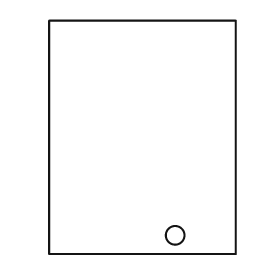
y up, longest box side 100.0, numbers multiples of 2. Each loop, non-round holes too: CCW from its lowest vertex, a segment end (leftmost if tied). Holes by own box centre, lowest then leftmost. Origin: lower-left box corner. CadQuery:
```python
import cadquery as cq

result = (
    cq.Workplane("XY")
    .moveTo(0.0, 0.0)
    .lineTo(80.0, 0.0)
    .lineTo(80.0, 100.0)
    .lineTo(0.0, 100.0)
    .close()
    .moveTo(54.0, 8.0)
    .circle(4.0)
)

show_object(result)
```